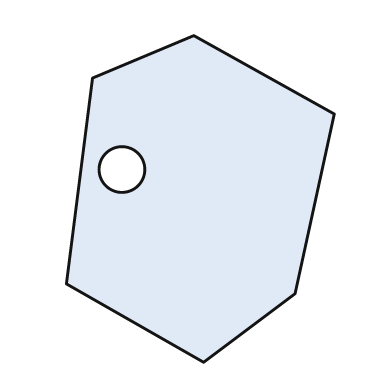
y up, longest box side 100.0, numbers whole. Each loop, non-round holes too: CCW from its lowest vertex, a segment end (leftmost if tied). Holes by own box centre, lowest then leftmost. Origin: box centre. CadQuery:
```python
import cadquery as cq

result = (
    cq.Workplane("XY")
    .moveTo(1.0, -50.0)
    .lineTo(29.0, -29.0)
    .lineTo(41.0, 26.0)
    .lineTo(-2.0, 50.0)
    .lineTo(-33.0, 37.0)
    .lineTo(-41.0, -26.0)
    .close()
    .moveTo(-24.0, 9.0)
    .circle(7.0)
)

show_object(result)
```